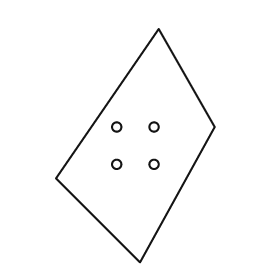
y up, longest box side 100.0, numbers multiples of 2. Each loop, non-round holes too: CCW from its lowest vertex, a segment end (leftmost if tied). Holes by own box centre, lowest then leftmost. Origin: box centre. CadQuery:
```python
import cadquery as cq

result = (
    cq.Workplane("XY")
    .moveTo(2.0, -50.0)
    .lineTo(34.0, 8.0)
    .lineTo(10.0, 50.0)
    .lineTo(-34.0, -14.0)
    .close()
    .moveTo(-8.0, -8.0)
    .circle(2.0)
    .moveTo(8.0, -8.0)
    .circle(2.0)
    .moveTo(-8.0, 8.0)
    .circle(2.0)
    .moveTo(8.0, 8.0)
    .circle(2.0)
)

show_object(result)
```